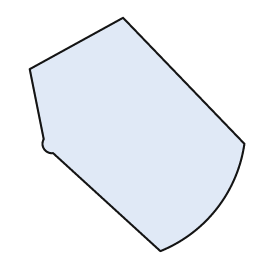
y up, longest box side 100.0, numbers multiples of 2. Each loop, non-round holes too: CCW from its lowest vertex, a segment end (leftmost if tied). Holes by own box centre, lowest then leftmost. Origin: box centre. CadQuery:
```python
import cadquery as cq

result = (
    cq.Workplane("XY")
    .moveTo(10.0, -50.0)
    .threePointArc((34.0, -32.0), (46.0, -4.0))
    .lineTo(-6.0, 50.0)
    .lineTo(-46.0, 28.0)
    .lineTo(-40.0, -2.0)
    .threePointArc((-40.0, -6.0), (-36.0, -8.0))
    .close()
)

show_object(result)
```